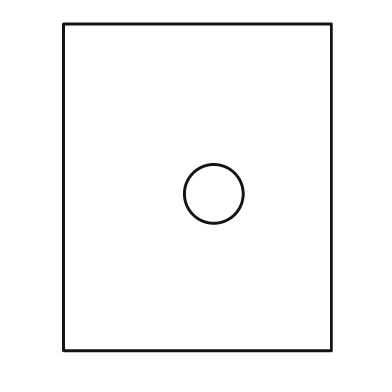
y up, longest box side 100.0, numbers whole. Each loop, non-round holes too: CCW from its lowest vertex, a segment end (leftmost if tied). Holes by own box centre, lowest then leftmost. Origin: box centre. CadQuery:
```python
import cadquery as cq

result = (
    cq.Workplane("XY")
    .moveTo(-41.0, -50.0)
    .lineTo(41.0, -50.0)
    .lineTo(41.0, 50.0)
    .lineTo(-41.0, 50.0)
    .close()
    .moveTo(5.0, -2.0)
    .circle(9.0)
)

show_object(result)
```